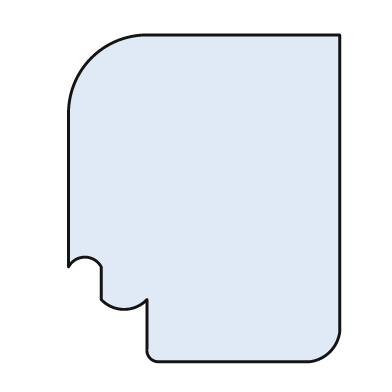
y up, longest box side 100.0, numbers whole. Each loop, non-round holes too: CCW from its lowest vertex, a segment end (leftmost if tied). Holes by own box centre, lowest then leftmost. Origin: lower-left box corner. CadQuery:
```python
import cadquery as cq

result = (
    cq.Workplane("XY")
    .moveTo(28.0, 0.0)
    .lineTo(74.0, 0.0)
    .threePointArc((80.0, 3.0), (83.0, 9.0))
    .lineTo(83.0, 100.0)
    .lineTo(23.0, 100.0)
    .threePointArc((7.0, 93.0), (0.0, 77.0))
    .lineTo(0.0, 29.0)
    .threePointArc((5.0, 32.0), (10.0, 29.0))
    .lineTo(10.0, 19.0)
    .threePointArc((17.0, 16.0), (24.0, 19.0))
    .lineTo(24.0, 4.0)
    .threePointArc((25.0, 1.0), (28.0, 0.0))
    .close()
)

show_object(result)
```